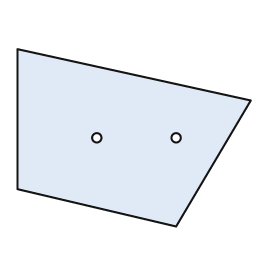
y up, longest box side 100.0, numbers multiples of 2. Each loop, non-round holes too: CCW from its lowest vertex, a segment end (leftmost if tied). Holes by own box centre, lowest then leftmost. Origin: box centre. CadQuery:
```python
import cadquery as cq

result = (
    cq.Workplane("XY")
    .moveTo(18.0, -38.0)
    .lineTo(50.0, 16.0)
    .lineTo(-50.0, 38.0)
    .lineTo(-50.0, -22.0)
    .close()
    .moveTo(-16.0, 0.0)
    .circle(2.0)
    .moveTo(18.0, 0.0)
    .circle(2.0)
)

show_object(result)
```